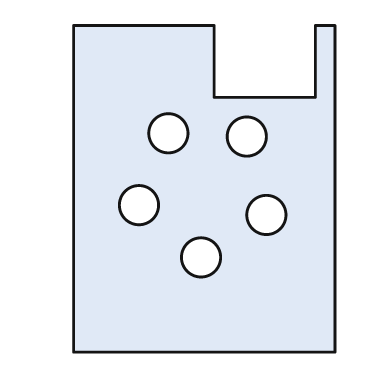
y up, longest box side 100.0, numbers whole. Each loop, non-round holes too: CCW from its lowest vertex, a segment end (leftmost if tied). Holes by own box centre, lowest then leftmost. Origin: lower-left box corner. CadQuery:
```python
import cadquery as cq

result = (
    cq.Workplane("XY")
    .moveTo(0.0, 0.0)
    .lineTo(80.0, 0.0)
    .lineTo(80.0, 100.0)
    .lineTo(74.0, 100.0)
    .lineTo(74.0, 78.0)
    .lineTo(43.0, 78.0)
    .lineTo(43.0, 100.0)
    .lineTo(0.0, 100.0)
    .close()
    .moveTo(39.0, 29.0)
    .circle(6.0)
    .moveTo(59.0, 42.0)
    .circle(6.0)
    .moveTo(20.0, 45.0)
    .circle(6.0)
    .moveTo(53.0, 66.0)
    .circle(6.0)
    .moveTo(29.0, 67.0)
    .circle(6.0)
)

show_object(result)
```